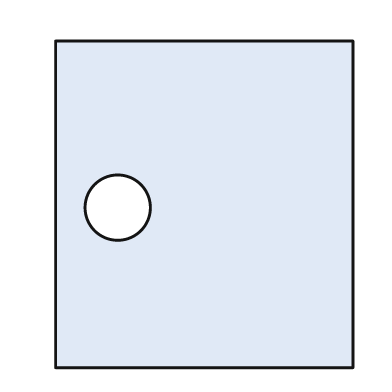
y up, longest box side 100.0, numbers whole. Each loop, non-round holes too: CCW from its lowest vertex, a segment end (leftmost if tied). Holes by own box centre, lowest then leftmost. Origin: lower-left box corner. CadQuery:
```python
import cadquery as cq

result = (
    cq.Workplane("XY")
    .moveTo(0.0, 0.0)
    .lineTo(91.0, 0.0)
    .lineTo(91.0, 100.0)
    .lineTo(0.0, 100.0)
    .close()
    .moveTo(19.0, 49.0)
    .circle(10.0)
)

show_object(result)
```